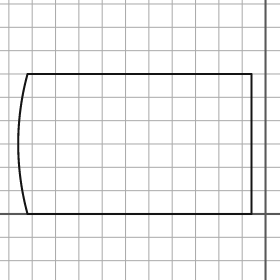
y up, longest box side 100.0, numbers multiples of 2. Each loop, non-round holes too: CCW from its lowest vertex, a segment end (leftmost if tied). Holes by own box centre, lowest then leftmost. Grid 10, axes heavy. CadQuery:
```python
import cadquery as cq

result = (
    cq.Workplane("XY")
    .moveTo(-102.0, 0.0)
    .lineTo(-6.0, 0.0)
    .lineTo(-6.0, 60.0)
    .lineTo(-102.0, 60.0)
    .threePointArc((-106.0, 30.0), (-102.0, 0.0))
    .close()
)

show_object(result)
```